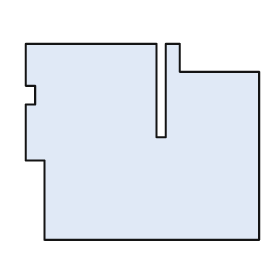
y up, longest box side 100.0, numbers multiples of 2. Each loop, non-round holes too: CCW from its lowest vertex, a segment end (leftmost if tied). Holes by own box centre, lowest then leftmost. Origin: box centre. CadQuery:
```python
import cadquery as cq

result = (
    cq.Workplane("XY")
    .moveTo(-42.0, -42.0)
    .lineTo(50.0, -42.0)
    .lineTo(50.0, 30.0)
    .lineTo(16.0, 30.0)
    .lineTo(16.0, 42.0)
    .lineTo(10.0, 42.0)
    .lineTo(10.0, 2.0)
    .lineTo(6.0, 2.0)
    .lineTo(6.0, 42.0)
    .lineTo(-50.0, 42.0)
    .lineTo(-50.0, 24.0)
    .lineTo(-46.0, 24.0)
    .lineTo(-46.0, 16.0)
    .lineTo(-50.0, 16.0)
    .lineTo(-50.0, -8.0)
    .lineTo(-42.0, -8.0)
    .close()
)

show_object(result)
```